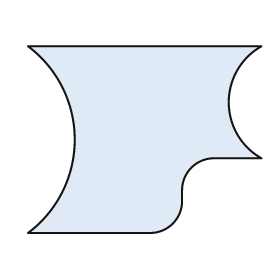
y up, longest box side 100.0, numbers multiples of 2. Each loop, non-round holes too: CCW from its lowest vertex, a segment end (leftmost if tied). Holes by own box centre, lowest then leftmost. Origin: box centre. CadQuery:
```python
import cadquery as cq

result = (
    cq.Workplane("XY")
    .moveTo(-50.0, -40.0)
    .lineTo(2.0, -40.0)
    .threePointArc((12.0, -36.0), (16.0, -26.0))
    .lineTo(16.0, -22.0)
    .threePointArc((20.0, -12.0), (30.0, -8.0))
    .lineTo(50.0, -8.0)
    .threePointArc((36.0, 16.0), (50.0, 40.0))
    .lineTo(-50.0, 40.0)
    .threePointArc((-30.0, 0.0), (-50.0, -40.0))
    .close()
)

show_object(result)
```